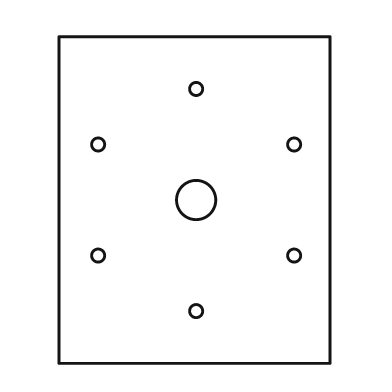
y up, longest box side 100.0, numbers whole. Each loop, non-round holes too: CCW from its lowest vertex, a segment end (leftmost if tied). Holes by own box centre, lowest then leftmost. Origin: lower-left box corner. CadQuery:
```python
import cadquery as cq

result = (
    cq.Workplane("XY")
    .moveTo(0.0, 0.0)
    .lineTo(83.0, 0.0)
    .lineTo(83.0, 100.0)
    .lineTo(0.0, 100.0)
    .close()
    .moveTo(42.0, 16.0)
    .circle(2.0)
    .moveTo(12.0, 33.0)
    .circle(2.0)
    .moveTo(72.0, 33.0)
    .circle(2.0)
    .moveTo(42.0, 50.0)
    .circle(6.0)
    .moveTo(12.0, 67.0)
    .circle(2.0)
    .moveTo(72.0, 67.0)
    .circle(2.0)
    .moveTo(42.0, 84.0)
    .circle(2.0)
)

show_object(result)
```